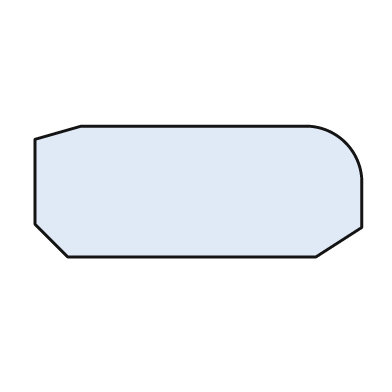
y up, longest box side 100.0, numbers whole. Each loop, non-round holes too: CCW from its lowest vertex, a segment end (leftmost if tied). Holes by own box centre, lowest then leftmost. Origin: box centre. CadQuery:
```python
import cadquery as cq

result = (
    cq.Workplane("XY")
    .moveTo(-40.0, -20.0)
    .lineTo(36.0, -20.0)
    .lineTo(50.0, -11.0)
    .lineTo(50.0, 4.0)
    .threePointArc((45.0, 15.0), (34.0, 20.0))
    .lineTo(-36.0, 20.0)
    .lineTo(-50.0, 16.0)
    .lineTo(-50.0, -10.0)
    .close()
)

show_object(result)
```